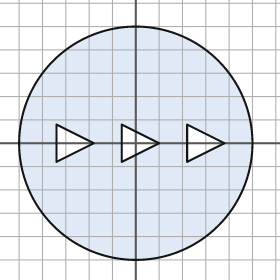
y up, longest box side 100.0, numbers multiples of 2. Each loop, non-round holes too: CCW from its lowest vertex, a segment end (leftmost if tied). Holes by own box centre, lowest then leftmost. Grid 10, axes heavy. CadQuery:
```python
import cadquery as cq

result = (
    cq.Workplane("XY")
    .moveTo(0.0, 0.0)
    .circle(50.0)
    .moveTo(-34.0, -8.0)
    .lineTo(-18.0, 0.0)
    .lineTo(-34.0, 8.0)
    .close()
    .moveTo(-6.0, -8.0)
    .lineTo(10.0, 0.0)
    .lineTo(-6.0, 8.0)
    .close()
    .moveTo(22.0, -8.0)
    .lineTo(38.0, 0.0)
    .lineTo(22.0, 8.0)
    .close()
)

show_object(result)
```